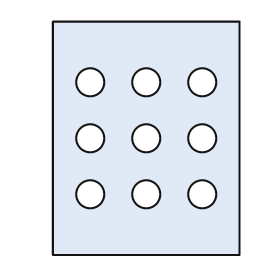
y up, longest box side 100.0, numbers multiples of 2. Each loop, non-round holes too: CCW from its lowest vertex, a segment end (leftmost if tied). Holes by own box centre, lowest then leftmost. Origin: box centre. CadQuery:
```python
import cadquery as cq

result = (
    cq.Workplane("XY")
    .moveTo(-40.0, -50.0)
    .lineTo(40.0, -50.0)
    .lineTo(40.0, 50.0)
    .lineTo(-40.0, 50.0)
    .close()
    .moveTo(-24.0, -24.0)
    .circle(6.0)
    .moveTo(0.0, -24.0)
    .circle(6.0)
    .moveTo(24.0, -24.0)
    .circle(6.0)
    .moveTo(-24.0, 0.0)
    .circle(6.0)
    .moveTo(0.0, 0.0)
    .circle(6.0)
    .moveTo(24.0, 0.0)
    .circle(6.0)
    .moveTo(-24.0, 24.0)
    .circle(6.0)
    .moveTo(0.0, 24.0)
    .circle(6.0)
    .moveTo(24.0, 24.0)
    .circle(6.0)
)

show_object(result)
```